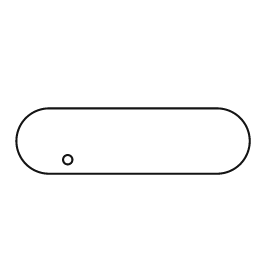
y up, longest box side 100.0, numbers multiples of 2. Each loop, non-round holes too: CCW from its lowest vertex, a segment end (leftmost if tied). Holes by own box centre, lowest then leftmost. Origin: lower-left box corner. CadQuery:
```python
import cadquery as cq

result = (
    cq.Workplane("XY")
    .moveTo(14.0, 0.0)
    .lineTo(86.0, 0.0)
    .threePointArc((100.0, 14.0), (86.0, 28.0))
    .lineTo(14.0, 28.0)
    .threePointArc((0.0, 14.0), (14.0, 0.0))
    .close()
    .moveTo(22.0, 6.0)
    .circle(2.0)
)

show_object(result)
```